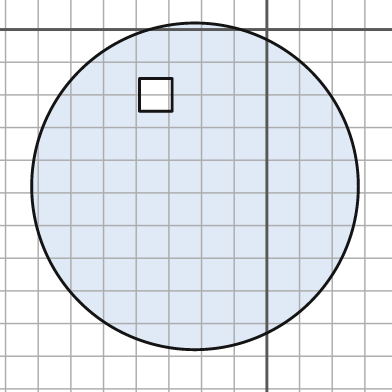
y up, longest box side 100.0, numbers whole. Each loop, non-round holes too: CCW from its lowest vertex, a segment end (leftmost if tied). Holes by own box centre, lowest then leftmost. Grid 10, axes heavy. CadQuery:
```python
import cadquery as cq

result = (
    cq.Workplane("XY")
    .moveTo(-22.0, -48.0)
    .circle(50.0)
    .moveTo(-39.0, -25.0)
    .lineTo(-29.0, -25.0)
    .lineTo(-29.0, -15.0)
    .lineTo(-39.0, -15.0)
    .close()
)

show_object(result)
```